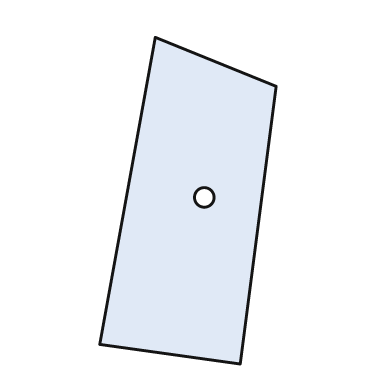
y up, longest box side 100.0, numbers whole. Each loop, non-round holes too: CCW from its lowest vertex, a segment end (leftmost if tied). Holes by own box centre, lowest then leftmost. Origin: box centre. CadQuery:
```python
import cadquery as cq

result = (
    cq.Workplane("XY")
    .moveTo(16.0, -50.0)
    .lineTo(27.0, 35.0)
    .lineTo(-10.0, 50.0)
    .lineTo(-27.0, -44.0)
    .close()
    .moveTo(5.0, 1.0)
    .circle(3.0)
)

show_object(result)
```